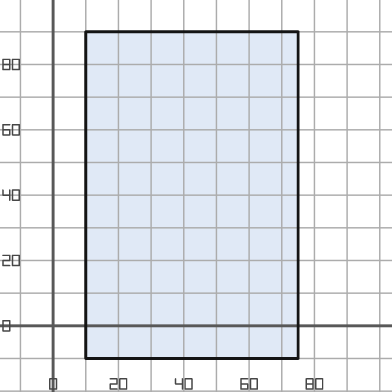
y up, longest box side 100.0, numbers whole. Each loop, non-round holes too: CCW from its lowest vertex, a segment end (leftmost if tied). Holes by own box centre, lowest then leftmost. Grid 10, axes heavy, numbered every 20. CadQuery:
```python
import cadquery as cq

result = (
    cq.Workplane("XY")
    .moveTo(10.0, -10.0)
    .lineTo(75.0, -10.0)
    .lineTo(75.0, 90.0)
    .lineTo(10.0, 90.0)
    .close()
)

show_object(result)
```